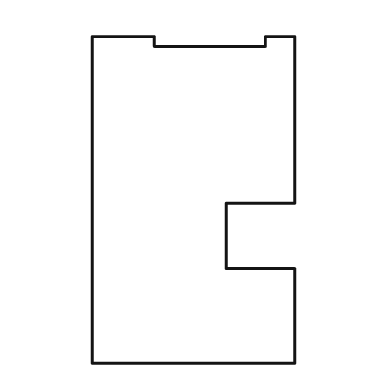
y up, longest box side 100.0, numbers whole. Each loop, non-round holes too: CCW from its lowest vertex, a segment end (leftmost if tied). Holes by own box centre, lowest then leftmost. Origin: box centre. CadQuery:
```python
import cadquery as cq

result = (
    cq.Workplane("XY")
    .moveTo(-31.0, -50.0)
    .lineTo(31.0, -50.0)
    .lineTo(31.0, -21.0)
    .lineTo(10.0, -21.0)
    .lineTo(10.0, -1.0)
    .lineTo(31.0, -1.0)
    .lineTo(31.0, 50.0)
    .lineTo(22.0, 50.0)
    .lineTo(22.0, 47.0)
    .lineTo(-12.0, 47.0)
    .lineTo(-12.0, 50.0)
    .lineTo(-31.0, 50.0)
    .close()
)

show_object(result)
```